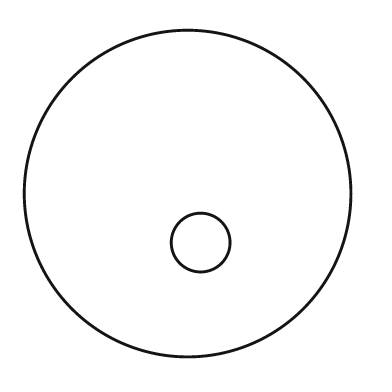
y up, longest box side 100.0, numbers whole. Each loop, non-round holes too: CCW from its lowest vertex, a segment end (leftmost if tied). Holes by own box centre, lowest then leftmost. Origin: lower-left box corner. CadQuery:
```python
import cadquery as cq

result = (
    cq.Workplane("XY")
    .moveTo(50.0, 50.0)
    .circle(50.0)
    .moveTo(54.0, 35.0)
    .circle(9.0)
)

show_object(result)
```